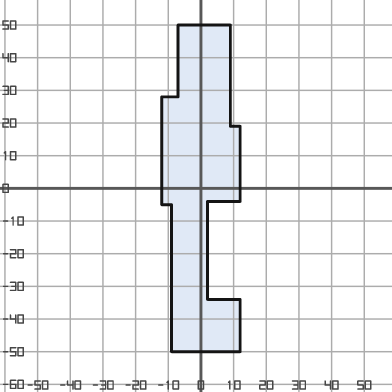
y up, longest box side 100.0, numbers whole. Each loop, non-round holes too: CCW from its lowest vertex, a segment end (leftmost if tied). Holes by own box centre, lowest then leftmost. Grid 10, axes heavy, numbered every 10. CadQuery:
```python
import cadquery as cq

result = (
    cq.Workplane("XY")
    .moveTo(-9.0, -50.0)
    .lineTo(12.0, -50.0)
    .lineTo(12.0, -34.0)
    .lineTo(2.0, -34.0)
    .lineTo(2.0, -4.0)
    .lineTo(12.0, -4.0)
    .lineTo(12.0, 19.0)
    .lineTo(9.0, 19.0)
    .lineTo(9.0, 50.0)
    .lineTo(-7.0, 50.0)
    .lineTo(-7.0, 28.0)
    .lineTo(-12.0, 28.0)
    .lineTo(-12.0, -5.0)
    .lineTo(-9.0, -5.0)
    .close()
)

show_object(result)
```